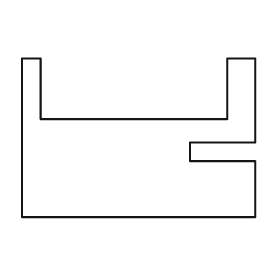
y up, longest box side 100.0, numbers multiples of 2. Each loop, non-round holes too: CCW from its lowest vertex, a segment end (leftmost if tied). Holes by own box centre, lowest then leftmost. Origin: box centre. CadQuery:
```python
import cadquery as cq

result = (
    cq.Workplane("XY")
    .moveTo(-50.0, -34.0)
    .lineTo(50.0, -34.0)
    .lineTo(50.0, -10.0)
    .lineTo(22.0, -10.0)
    .lineTo(22.0, -2.0)
    .lineTo(50.0, -2.0)
    .lineTo(50.0, 34.0)
    .lineTo(38.0, 34.0)
    .lineTo(38.0, 8.0)
    .lineTo(-42.0, 8.0)
    .lineTo(-42.0, 34.0)
    .lineTo(-50.0, 34.0)
    .close()
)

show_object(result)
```